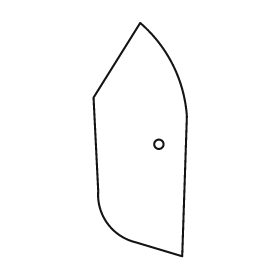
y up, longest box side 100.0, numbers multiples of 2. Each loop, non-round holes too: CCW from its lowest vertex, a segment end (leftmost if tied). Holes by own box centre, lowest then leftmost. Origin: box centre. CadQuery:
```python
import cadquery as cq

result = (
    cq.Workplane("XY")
    .moveTo(18.0, -50.0)
    .lineTo(20.0, 10.0)
    .threePointArc((14.0, 32.0), (0.0, 50.0))
    .lineTo(-20.0, 18.0)
    .lineTo(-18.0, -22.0)
    .threePointArc((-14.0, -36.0), (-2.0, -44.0))
    .close()
    .moveTo(8.0, -2.0)
    .circle(2.0)
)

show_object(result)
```